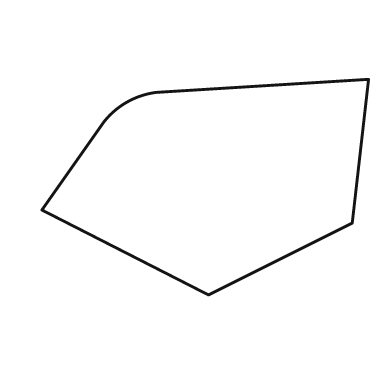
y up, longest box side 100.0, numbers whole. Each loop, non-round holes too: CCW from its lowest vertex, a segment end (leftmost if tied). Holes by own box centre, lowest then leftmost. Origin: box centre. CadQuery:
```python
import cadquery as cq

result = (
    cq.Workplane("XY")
    .moveTo(1.0, -33.0)
    .lineTo(45.0, -11.0)
    .lineTo(50.0, 33.0)
    .lineTo(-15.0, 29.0)
    .threePointArc((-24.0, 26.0), (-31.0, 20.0))
    .lineTo(-50.0, -7.0)
    .close()
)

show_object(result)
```